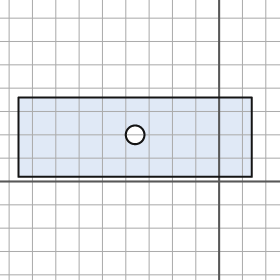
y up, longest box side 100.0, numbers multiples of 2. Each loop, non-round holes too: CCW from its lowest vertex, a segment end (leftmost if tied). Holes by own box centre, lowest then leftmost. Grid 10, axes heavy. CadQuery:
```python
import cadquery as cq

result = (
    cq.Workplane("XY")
    .moveTo(-86.0, 2.0)
    .lineTo(14.0, 2.0)
    .lineTo(14.0, 36.0)
    .lineTo(-86.0, 36.0)
    .close()
    .moveTo(-36.0, 20.0)
    .circle(4.0)
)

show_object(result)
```